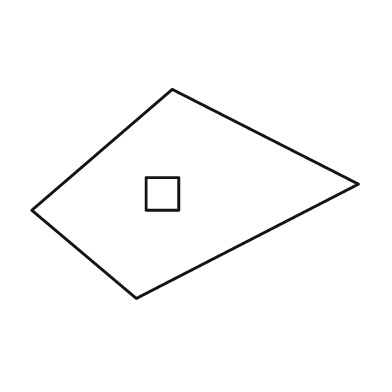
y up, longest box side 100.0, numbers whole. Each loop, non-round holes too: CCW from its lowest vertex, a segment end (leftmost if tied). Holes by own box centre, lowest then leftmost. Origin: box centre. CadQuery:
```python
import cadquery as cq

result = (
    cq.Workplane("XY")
    .moveTo(-18.0, -32.0)
    .lineTo(50.0, 3.0)
    .lineTo(-7.0, 32.0)
    .lineTo(-50.0, -5.0)
    .close()
    .moveTo(-15.0, -5.0)
    .lineTo(-5.0, -5.0)
    .lineTo(-5.0, 5.0)
    .lineTo(-15.0, 5.0)
    .close()
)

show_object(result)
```